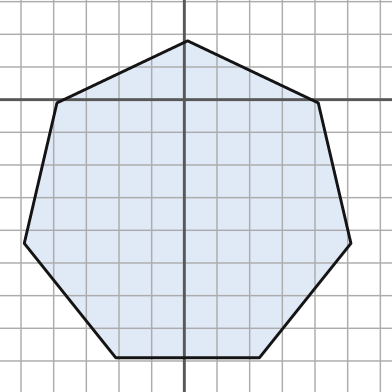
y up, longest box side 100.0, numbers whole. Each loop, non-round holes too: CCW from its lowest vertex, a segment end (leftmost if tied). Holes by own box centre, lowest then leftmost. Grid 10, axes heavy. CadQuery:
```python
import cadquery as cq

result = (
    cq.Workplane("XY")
    .moveTo(-21.0, -79.0)
    .lineTo(23.0, -79.0)
    .lineTo(51.0, -44.0)
    .lineTo(41.0, -1.0)
    .lineTo(1.0, 18.0)
    .lineTo(-39.0, -1.0)
    .lineTo(-49.0, -44.0)
    .close()
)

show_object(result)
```